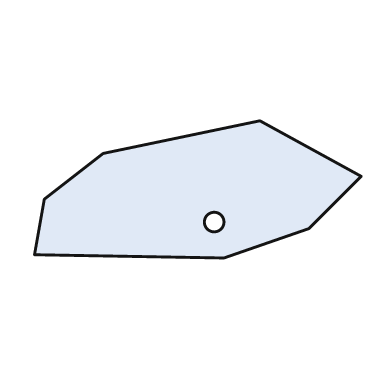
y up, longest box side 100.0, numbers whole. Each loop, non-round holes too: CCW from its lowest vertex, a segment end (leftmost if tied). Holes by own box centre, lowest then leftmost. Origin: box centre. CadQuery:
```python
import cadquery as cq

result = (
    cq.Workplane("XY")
    .moveTo(8.0, -21.0)
    .lineTo(34.0, -12.0)
    .lineTo(50.0, 4.0)
    .lineTo(19.0, 21.0)
    .lineTo(-29.0, 11.0)
    .lineTo(-47.0, -3.0)
    .lineTo(-50.0, -20.0)
    .close()
    .moveTo(5.0, -10.0)
    .circle(3.0)
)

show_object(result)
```